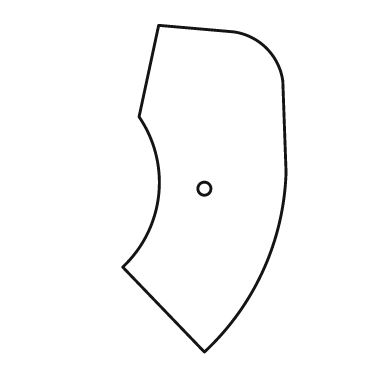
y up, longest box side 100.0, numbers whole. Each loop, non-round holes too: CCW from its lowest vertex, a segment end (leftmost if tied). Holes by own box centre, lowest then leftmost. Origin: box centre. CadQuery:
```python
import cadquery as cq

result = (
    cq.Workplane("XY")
    .moveTo(0.0, -50.0)
    .threePointArc((18.0, -25.0), (25.0, 5.0))
    .lineTo(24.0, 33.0)
    .threePointArc((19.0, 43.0), (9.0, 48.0))
    .lineTo(-14.0, 50.0)
    .lineTo(-20.0, 22.0)
    .threePointArc((-14.0, -2.0), (-25.0, -24.0))
    .close()
    .moveTo(0.0, 0.0)
    .circle(2.0)
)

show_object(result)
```